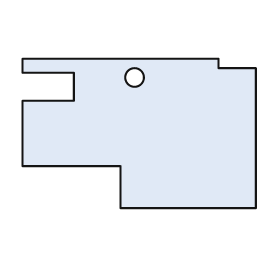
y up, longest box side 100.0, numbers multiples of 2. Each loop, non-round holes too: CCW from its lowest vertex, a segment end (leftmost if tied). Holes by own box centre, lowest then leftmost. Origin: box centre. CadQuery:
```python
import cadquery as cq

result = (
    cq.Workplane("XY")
    .moveTo(-8.0, -32.0)
    .lineTo(50.0, -32.0)
    .lineTo(50.0, 28.0)
    .lineTo(34.0, 28.0)
    .lineTo(34.0, 32.0)
    .lineTo(-50.0, 32.0)
    .lineTo(-50.0, 26.0)
    .lineTo(-28.0, 26.0)
    .lineTo(-28.0, 14.0)
    .lineTo(-50.0, 14.0)
    .lineTo(-50.0, -14.0)
    .lineTo(-8.0, -14.0)
    .close()
    .moveTo(-2.0, 24.0)
    .circle(4.0)
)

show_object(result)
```